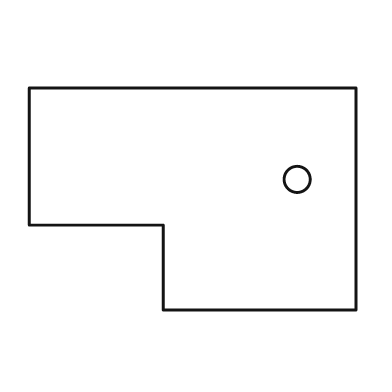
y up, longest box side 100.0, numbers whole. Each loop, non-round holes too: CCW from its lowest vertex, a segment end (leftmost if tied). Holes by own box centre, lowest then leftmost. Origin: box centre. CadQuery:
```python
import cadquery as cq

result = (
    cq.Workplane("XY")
    .moveTo(-9.0, -34.0)
    .lineTo(50.0, -34.0)
    .lineTo(50.0, 34.0)
    .lineTo(-50.0, 34.0)
    .lineTo(-50.0, -8.0)
    .lineTo(-9.0, -8.0)
    .close()
    .moveTo(32.0, 6.0)
    .circle(4.0)
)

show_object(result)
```